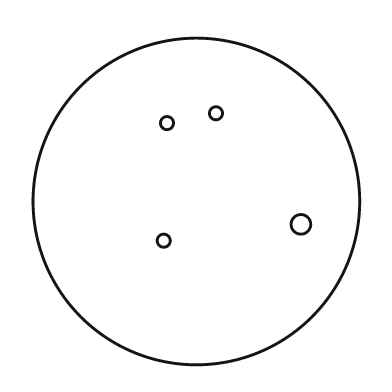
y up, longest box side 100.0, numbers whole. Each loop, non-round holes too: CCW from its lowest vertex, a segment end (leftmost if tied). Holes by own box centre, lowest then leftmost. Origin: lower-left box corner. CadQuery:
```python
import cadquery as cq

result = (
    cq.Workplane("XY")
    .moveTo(50.0, 50.0)
    .circle(50.0)
    .moveTo(40.0, 38.0)
    .circle(2.0)
    .moveTo(82.0, 43.0)
    .circle(3.0)
    .moveTo(41.0, 74.0)
    .circle(2.0)
    .moveTo(56.0, 77.0)
    .circle(2.0)
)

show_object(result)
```